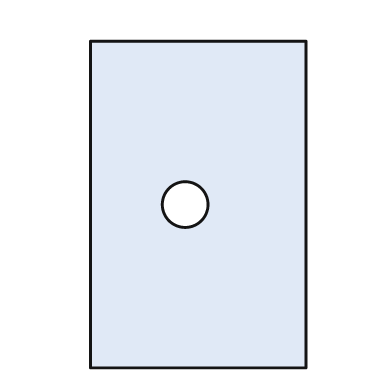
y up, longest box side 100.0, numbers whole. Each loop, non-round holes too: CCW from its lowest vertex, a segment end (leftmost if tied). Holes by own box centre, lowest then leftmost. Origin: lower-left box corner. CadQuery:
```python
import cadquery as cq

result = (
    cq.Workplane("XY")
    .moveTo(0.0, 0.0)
    .lineTo(66.0, 0.0)
    .lineTo(66.0, 100.0)
    .lineTo(0.0, 100.0)
    .close()
    .moveTo(29.0, 50.0)
    .circle(7.0)
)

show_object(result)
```